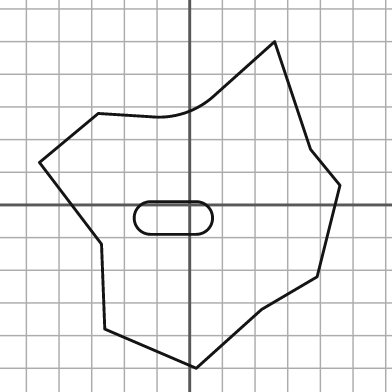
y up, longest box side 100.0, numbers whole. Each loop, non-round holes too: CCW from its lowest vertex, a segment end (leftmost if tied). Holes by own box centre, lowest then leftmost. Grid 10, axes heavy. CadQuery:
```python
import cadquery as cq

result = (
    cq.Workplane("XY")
    .moveTo(2.0, -50.0)
    .lineTo(22.0, -32.0)
    .lineTo(39.0, -22.0)
    .lineTo(46.0, 6.0)
    .lineTo(37.0, 17.0)
    .lineTo(26.0, 50.0)
    .lineTo(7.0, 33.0)
    .threePointArc((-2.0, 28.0), (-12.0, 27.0))
    .lineTo(-28.0, 28.0)
    .lineTo(-46.0, 13.0)
    .lineTo(-27.0, -12.0)
    .lineTo(-26.0, -38.0)
    .close()
    .moveTo(-12.0, -9.0)
    .lineTo(2.0, -9.0)
    .threePointArc((7.0, -4.0), (2.0, 1.0))
    .lineTo(-12.0, 1.0)
    .threePointArc((-17.0, -4.0), (-12.0, -9.0))
    .close()
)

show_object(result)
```